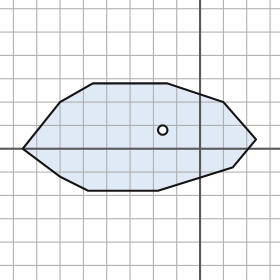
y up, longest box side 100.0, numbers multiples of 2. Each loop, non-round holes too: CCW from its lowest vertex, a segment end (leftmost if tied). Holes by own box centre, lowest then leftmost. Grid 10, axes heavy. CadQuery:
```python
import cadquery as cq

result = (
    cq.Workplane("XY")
    .moveTo(-48.0, -18.0)
    .lineTo(-18.0, -18.0)
    .lineTo(14.0, -8.0)
    .lineTo(24.0, 4.0)
    .lineTo(10.0, 20.0)
    .lineTo(-14.0, 28.0)
    .lineTo(-46.0, 28.0)
    .lineTo(-60.0, 20.0)
    .lineTo(-76.0, 0.0)
    .lineTo(-60.0, -12.0)
    .close()
    .moveTo(-16.0, 8.0)
    .circle(2.0)
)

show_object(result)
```